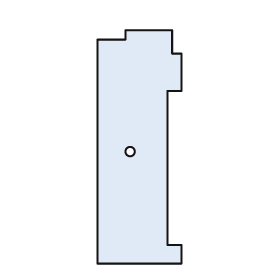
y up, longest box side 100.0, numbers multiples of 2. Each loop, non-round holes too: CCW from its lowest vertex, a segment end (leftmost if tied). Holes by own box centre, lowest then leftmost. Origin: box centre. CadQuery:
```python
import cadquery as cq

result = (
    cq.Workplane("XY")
    .moveTo(-18.0, -50.0)
    .lineTo(18.0, -50.0)
    .lineTo(18.0, -42.0)
    .lineTo(12.0, -42.0)
    .lineTo(12.0, 24.0)
    .lineTo(18.0, 24.0)
    .lineTo(18.0, 40.0)
    .lineTo(14.0, 40.0)
    .lineTo(14.0, 50.0)
    .lineTo(-6.0, 50.0)
    .lineTo(-6.0, 46.0)
    .lineTo(-18.0, 46.0)
    .close()
    .moveTo(-4.0, -2.0)
    .circle(2.0)
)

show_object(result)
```